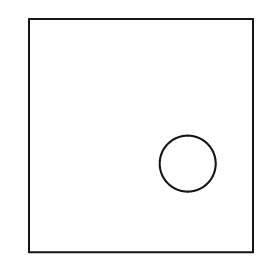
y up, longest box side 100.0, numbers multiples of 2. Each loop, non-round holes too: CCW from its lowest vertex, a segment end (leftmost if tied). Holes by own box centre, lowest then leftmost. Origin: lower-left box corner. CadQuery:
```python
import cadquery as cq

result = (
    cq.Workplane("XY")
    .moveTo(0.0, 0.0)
    .lineTo(96.0, 0.0)
    .lineTo(96.0, 100.0)
    .lineTo(0.0, 100.0)
    .close()
    .moveTo(68.0, 38.0)
    .circle(12.0)
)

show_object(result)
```